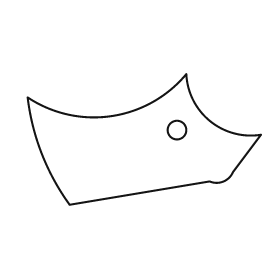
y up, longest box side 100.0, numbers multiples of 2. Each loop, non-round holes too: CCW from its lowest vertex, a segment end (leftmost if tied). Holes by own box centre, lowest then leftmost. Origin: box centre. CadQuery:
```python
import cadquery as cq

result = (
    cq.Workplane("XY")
    .moveTo(-32.0, -28.0)
    .lineTo(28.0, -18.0)
    .threePointArc((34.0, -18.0), (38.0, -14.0))
    .lineTo(50.0, 2.0)
    .threePointArc((28.0, 8.0), (18.0, 28.0))
    .threePointArc((-14.0, 10.0), (-50.0, 18.0))
    .threePointArc((-44.0, -6.0), (-32.0, -28.0))
    .close()
    .moveTo(14.0, 4.0)
    .circle(4.0)
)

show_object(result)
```